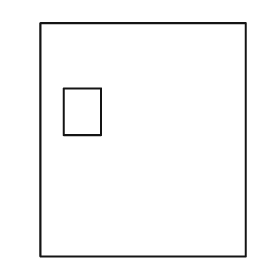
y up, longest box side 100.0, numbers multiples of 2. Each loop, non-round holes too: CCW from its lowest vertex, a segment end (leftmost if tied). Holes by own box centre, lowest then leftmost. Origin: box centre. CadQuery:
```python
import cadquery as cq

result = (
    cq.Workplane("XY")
    .moveTo(-44.0, -50.0)
    .lineTo(44.0, -50.0)
    .lineTo(44.0, 50.0)
    .lineTo(-44.0, 50.0)
    .close()
    .moveTo(-34.0, 2.0)
    .lineTo(-18.0, 2.0)
    .lineTo(-18.0, 22.0)
    .lineTo(-34.0, 22.0)
    .close()
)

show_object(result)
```